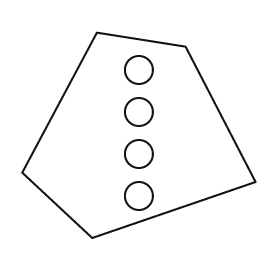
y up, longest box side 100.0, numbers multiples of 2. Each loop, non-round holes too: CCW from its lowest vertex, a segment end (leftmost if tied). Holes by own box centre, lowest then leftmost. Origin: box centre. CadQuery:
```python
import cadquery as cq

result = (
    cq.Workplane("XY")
    .moveTo(-20.0, -44.0)
    .lineTo(50.0, -20.0)
    .lineTo(20.0, 38.0)
    .lineTo(-18.0, 44.0)
    .lineTo(-50.0, -16.0)
    .close()
    .moveTo(0.0, -26.0)
    .circle(6.0)
    .moveTo(0.0, -8.0)
    .circle(6.0)
    .moveTo(0.0, 10.0)
    .circle(6.0)
    .moveTo(0.0, 28.0)
    .circle(6.0)
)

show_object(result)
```